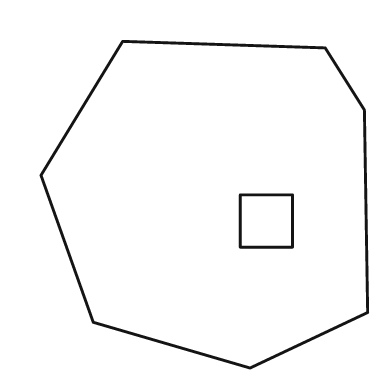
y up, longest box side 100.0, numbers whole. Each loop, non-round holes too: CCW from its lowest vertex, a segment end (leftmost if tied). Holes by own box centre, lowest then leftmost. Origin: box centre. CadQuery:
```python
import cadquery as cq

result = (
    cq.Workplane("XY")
    .moveTo(14.0, -50.0)
    .lineTo(50.0, -33.0)
    .lineTo(49.0, 29.0)
    .lineTo(37.0, 48.0)
    .lineTo(-25.0, 50.0)
    .lineTo(-50.0, 9.0)
    .lineTo(-34.0, -36.0)
    .close()
    .moveTo(11.0, -13.0)
    .lineTo(27.0, -13.0)
    .lineTo(27.0, 3.0)
    .lineTo(11.0, 3.0)
    .close()
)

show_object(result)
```